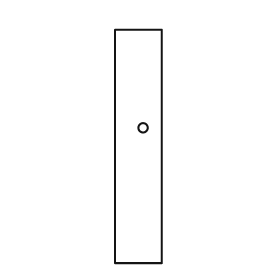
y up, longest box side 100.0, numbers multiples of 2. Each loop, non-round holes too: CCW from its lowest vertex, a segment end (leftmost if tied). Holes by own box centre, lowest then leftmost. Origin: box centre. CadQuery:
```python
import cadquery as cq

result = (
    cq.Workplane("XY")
    .moveTo(-10.0, -50.0)
    .lineTo(10.0, -50.0)
    .lineTo(10.0, 50.0)
    .lineTo(-10.0, 50.0)
    .close()
    .moveTo(2.0, 8.0)
    .circle(2.0)
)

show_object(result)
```